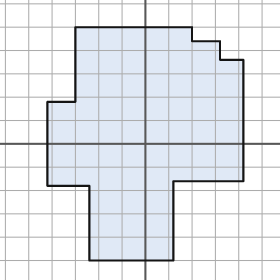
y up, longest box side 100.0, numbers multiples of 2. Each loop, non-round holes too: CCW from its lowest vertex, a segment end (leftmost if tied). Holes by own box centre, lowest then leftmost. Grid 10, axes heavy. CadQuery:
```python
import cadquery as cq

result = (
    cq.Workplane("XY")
    .moveTo(-24.0, -50.0)
    .lineTo(12.0, -50.0)
    .lineTo(12.0, -16.0)
    .lineTo(42.0, -16.0)
    .lineTo(42.0, 36.0)
    .lineTo(32.0, 36.0)
    .lineTo(32.0, 44.0)
    .lineTo(20.0, 44.0)
    .lineTo(20.0, 50.0)
    .lineTo(-30.0, 50.0)
    .lineTo(-30.0, 18.0)
    .lineTo(-42.0, 18.0)
    .lineTo(-42.0, -18.0)
    .lineTo(-24.0, -18.0)
    .close()
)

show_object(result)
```